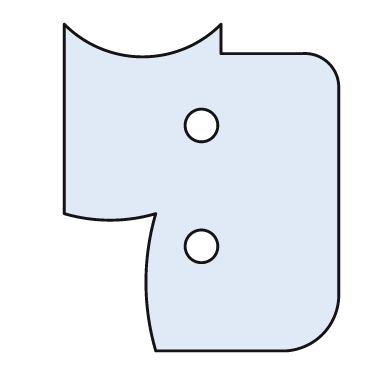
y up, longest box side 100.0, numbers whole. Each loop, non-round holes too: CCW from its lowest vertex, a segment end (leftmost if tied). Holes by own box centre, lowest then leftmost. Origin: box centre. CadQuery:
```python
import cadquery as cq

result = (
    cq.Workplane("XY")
    .moveTo(-14.0, -50.0)
    .lineTo(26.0, -50.0)
    .threePointArc((37.0, -45.0), (42.0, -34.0))
    .lineTo(42.0, 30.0)
    .threePointArc((39.0, 38.0), (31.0, 41.0))
    .lineTo(6.0, 41.0)
    .lineTo(6.0, 50.0)
    .threePointArc((-18.0, 40.0), (-42.0, 50.0))
    .lineTo(-42.0, -8.0)
    .threePointArc((-28.0, -10.0), (-14.0, -8.0))
    .threePointArc((-17.0, -29.0), (-14.0, -50.0))
    .close()
    .moveTo(0.0, -18.0)
    .circle(5.0)
    .moveTo(0.0, 19.0)
    .circle(5.0)
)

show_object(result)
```